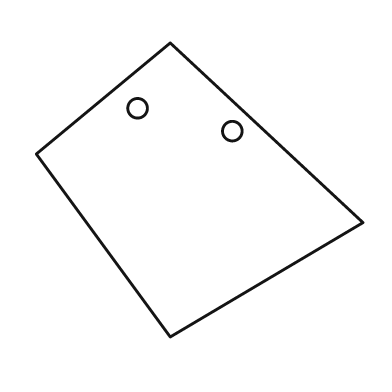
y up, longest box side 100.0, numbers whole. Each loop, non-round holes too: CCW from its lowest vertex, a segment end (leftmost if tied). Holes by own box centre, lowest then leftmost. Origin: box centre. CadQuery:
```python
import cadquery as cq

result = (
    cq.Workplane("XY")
    .moveTo(-9.0, -45.0)
    .lineTo(50.0, -10.0)
    .lineTo(-9.0, 45.0)
    .lineTo(-50.0, 11.0)
    .close()
    .moveTo(10.0, 18.0)
    .circle(3.0)
    .moveTo(-19.0, 25.0)
    .circle(3.0)
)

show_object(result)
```